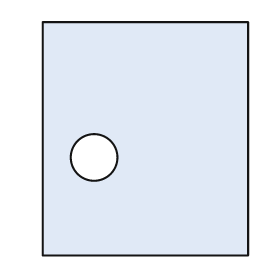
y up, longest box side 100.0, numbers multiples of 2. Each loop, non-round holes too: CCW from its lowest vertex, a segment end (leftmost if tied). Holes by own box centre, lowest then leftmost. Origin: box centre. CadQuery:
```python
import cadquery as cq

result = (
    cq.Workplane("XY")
    .moveTo(-44.0, -50.0)
    .lineTo(44.0, -50.0)
    .lineTo(44.0, 50.0)
    .lineTo(-44.0, 50.0)
    .close()
    .moveTo(-22.0, -8.0)
    .circle(10.0)
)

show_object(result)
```